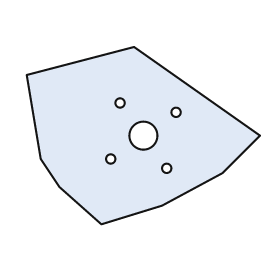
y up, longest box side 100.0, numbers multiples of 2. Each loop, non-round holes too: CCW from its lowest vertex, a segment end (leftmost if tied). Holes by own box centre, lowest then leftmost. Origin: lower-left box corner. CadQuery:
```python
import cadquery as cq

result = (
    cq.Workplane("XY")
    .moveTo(32.0, 0.0)
    .lineTo(58.0, 8.0)
    .lineTo(84.0, 22.0)
    .lineTo(100.0, 38.0)
    .lineTo(46.0, 76.0)
    .lineTo(0.0, 64.0)
    .lineTo(6.0, 28.0)
    .lineTo(14.0, 16.0)
    .close()
    .moveTo(60.0, 24.0)
    .circle(2.0)
    .moveTo(36.0, 28.0)
    .circle(2.0)
    .moveTo(50.0, 38.0)
    .circle(6.0)
    .moveTo(64.0, 48.0)
    .circle(2.0)
    .moveTo(40.0, 52.0)
    .circle(2.0)
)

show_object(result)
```